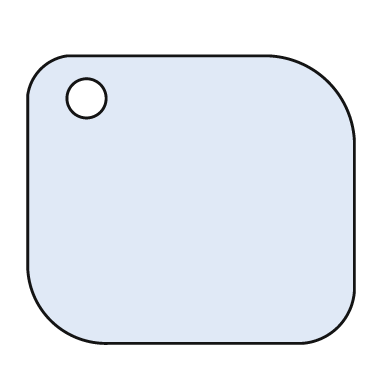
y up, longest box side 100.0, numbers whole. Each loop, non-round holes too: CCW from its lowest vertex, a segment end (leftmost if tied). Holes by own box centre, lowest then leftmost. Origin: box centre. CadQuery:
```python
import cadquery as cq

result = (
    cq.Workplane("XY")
    .moveTo(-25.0, -44.0)
    .lineTo(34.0, -44.0)
    .threePointArc((45.0, -39.0), (50.0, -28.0))
    .lineTo(50.0, 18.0)
    .threePointArc((42.0, 36.0), (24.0, 44.0))
    .lineTo(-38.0, 44.0)
    .threePointArc((-46.0, 40.0), (-50.0, 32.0))
    .lineTo(-50.0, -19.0)
    .threePointArc((-43.0, -37.0), (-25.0, -44.0))
    .close()
    .moveTo(-32.0, 31.0)
    .circle(6.0)
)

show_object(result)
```